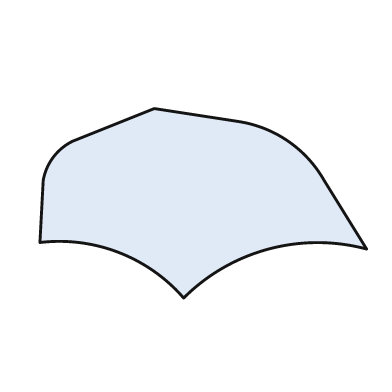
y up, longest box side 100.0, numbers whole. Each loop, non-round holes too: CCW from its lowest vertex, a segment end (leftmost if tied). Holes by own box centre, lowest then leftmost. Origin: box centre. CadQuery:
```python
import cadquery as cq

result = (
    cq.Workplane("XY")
    .moveTo(-6.0, -29.0)
    .threePointArc((20.0, -14.0), (50.0, -14.0))
    .lineTo(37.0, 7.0)
    .threePointArc((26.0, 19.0), (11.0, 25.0))
    .lineTo(-15.0, 29.0)
    .lineTo(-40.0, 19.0)
    .threePointArc((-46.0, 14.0), (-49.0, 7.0))
    .lineTo(-50.0, -12.0)
    .threePointArc((-26.0, -15.0), (-6.0, -29.0))
    .close()
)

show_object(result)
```